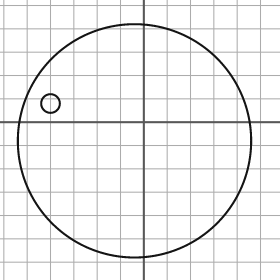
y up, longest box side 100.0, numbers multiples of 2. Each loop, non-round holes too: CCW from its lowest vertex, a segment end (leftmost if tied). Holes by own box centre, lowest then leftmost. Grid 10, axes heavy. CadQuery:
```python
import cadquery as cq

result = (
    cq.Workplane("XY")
    .moveTo(-4.0, -8.0)
    .circle(50.0)
    .moveTo(-40.0, 8.0)
    .circle(4.0)
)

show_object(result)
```